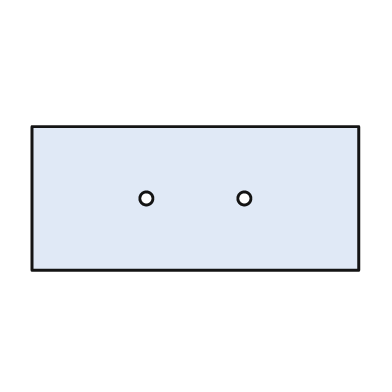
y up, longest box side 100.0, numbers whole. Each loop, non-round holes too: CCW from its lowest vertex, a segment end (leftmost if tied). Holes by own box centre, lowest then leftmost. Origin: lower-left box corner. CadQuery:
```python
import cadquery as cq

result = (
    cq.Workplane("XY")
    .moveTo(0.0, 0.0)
    .lineTo(100.0, 0.0)
    .lineTo(100.0, 44.0)
    .lineTo(0.0, 44.0)
    .close()
    .moveTo(35.0, 22.0)
    .circle(2.0)
    .moveTo(65.0, 22.0)
    .circle(2.0)
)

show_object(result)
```